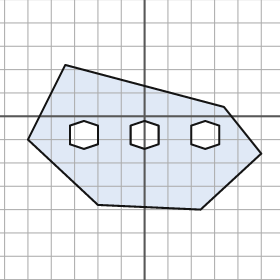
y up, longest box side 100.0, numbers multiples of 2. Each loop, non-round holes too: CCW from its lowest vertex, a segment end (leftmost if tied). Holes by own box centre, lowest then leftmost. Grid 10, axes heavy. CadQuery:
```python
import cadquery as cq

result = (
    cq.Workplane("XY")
    .moveTo(24.0, -40.0)
    .lineTo(50.0, -16.0)
    .lineTo(34.0, 4.0)
    .lineTo(-34.0, 22.0)
    .lineTo(-50.0, -10.0)
    .lineTo(-20.0, -38.0)
    .close()
    .moveTo(-26.0, -14.0)
    .lineTo(-20.0, -12.0)
    .lineTo(-20.0, -4.0)
    .lineTo(-26.0, -2.0)
    .lineTo(-32.0, -4.0)
    .lineTo(-32.0, -12.0)
    .close()
    .moveTo(0.0, -14.0)
    .lineTo(6.0, -12.0)
    .lineTo(6.0, -4.0)
    .lineTo(0.0, -2.0)
    .lineTo(-6.0, -4.0)
    .lineTo(-6.0, -12.0)
    .close()
    .moveTo(26.0, -14.0)
    .lineTo(32.0, -12.0)
    .lineTo(32.0, -4.0)
    .lineTo(26.0, -2.0)
    .lineTo(20.0, -4.0)
    .lineTo(20.0, -12.0)
    .close()
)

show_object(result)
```